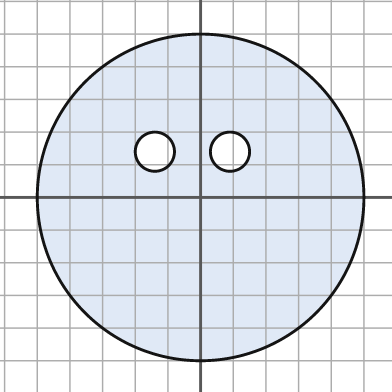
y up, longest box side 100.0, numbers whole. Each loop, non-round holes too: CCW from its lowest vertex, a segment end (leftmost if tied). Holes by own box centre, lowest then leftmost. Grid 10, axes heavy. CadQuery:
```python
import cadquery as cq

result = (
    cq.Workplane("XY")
    .moveTo(0.0, 0.0)
    .circle(50.0)
    .moveTo(-14.0, 14.0)
    .circle(6.0)
    .moveTo(9.0, 14.0)
    .circle(6.0)
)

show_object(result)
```